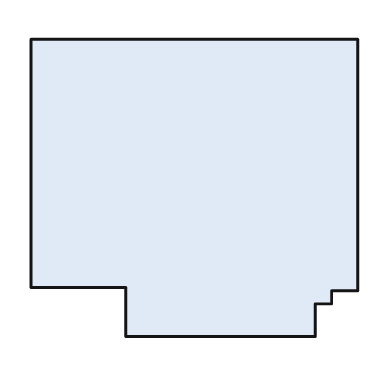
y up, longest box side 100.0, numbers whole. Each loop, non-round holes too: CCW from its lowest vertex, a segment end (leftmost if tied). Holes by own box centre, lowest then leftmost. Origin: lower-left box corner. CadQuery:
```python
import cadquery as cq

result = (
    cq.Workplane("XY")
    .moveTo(29.0, 0.0)
    .lineTo(87.0, 0.0)
    .lineTo(87.0, 10.0)
    .lineTo(92.0, 10.0)
    .lineTo(92.0, 14.0)
    .lineTo(100.0, 14.0)
    .lineTo(100.0, 91.0)
    .lineTo(0.0, 91.0)
    .lineTo(0.0, 15.0)
    .lineTo(29.0, 15.0)
    .close()
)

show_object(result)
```